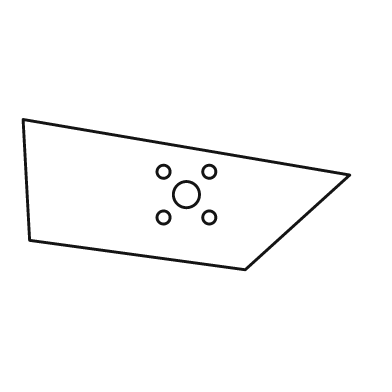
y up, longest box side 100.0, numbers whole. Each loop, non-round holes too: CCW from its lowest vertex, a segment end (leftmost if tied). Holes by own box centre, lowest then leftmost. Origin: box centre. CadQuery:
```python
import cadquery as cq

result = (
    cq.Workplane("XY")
    .moveTo(18.0, -23.0)
    .lineTo(50.0, 6.0)
    .lineTo(-50.0, 23.0)
    .lineTo(-48.0, -14.0)
    .close()
    .moveTo(-7.0, -7.0)
    .circle(2.0)
    .moveTo(7.0, -7.0)
    .circle(2.0)
    .moveTo(0.0, 0.0)
    .circle(4.0)
    .moveTo(-7.0, 7.0)
    .circle(2.0)
    .moveTo(7.0, 7.0)
    .circle(2.0)
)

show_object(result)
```